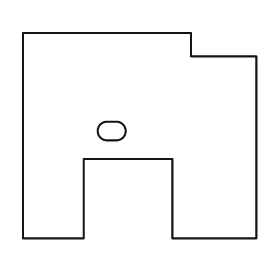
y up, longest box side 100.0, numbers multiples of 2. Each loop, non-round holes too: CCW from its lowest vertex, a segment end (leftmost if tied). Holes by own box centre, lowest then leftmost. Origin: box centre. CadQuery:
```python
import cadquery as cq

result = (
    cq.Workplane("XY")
    .moveTo(-50.0, -44.0)
    .lineTo(-24.0, -44.0)
    .lineTo(-24.0, -10.0)
    .lineTo(14.0, -10.0)
    .lineTo(14.0, -44.0)
    .lineTo(50.0, -44.0)
    .lineTo(50.0, 34.0)
    .lineTo(22.0, 34.0)
    .lineTo(22.0, 44.0)
    .lineTo(-50.0, 44.0)
    .close()
    .moveTo(-14.0, -2.0)
    .lineTo(-10.0, -2.0)
    .threePointArc((-6.0, 2.0), (-10.0, 6.0))
    .lineTo(-14.0, 6.0)
    .threePointArc((-18.0, 2.0), (-14.0, -2.0))
    .close()
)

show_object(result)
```